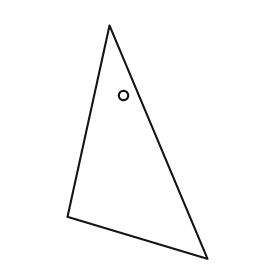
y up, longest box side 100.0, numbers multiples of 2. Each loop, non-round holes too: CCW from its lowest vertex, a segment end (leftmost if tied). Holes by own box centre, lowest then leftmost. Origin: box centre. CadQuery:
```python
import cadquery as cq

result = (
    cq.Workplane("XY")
    .moveTo(30.0, -50.0)
    .lineTo(-12.0, 50.0)
    .lineTo(-30.0, -32.0)
    .close()
    .moveTo(-6.0, 20.0)
    .circle(2.0)
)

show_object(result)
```